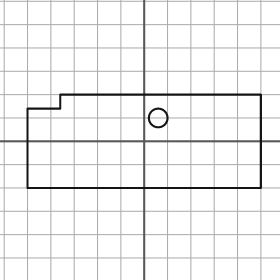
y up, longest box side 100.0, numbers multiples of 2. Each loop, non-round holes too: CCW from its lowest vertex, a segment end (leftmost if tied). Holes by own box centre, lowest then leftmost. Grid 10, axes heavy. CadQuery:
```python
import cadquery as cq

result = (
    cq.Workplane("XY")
    .moveTo(-50.0, -20.0)
    .lineTo(50.0, -20.0)
    .lineTo(50.0, 20.0)
    .lineTo(-36.0, 20.0)
    .lineTo(-36.0, 14.0)
    .lineTo(-50.0, 14.0)
    .close()
    .moveTo(6.0, 10.0)
    .circle(4.0)
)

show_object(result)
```